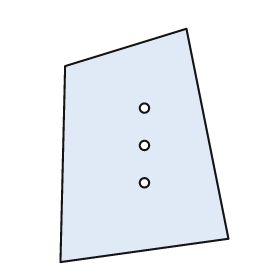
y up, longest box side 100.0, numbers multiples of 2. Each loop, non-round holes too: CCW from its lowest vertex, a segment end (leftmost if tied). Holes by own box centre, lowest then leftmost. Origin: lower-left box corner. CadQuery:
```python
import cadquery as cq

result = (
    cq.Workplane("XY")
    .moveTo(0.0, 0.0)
    .lineTo(72.0, 10.0)
    .lineTo(54.0, 100.0)
    .lineTo(2.0, 84.0)
    .close()
    .moveTo(36.0, 34.0)
    .circle(2.0)
    .moveTo(36.0, 50.0)
    .circle(2.0)
    .moveTo(36.0, 66.0)
    .circle(2.0)
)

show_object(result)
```